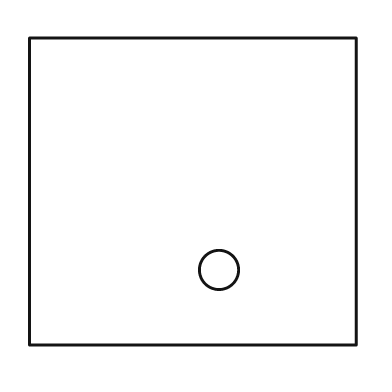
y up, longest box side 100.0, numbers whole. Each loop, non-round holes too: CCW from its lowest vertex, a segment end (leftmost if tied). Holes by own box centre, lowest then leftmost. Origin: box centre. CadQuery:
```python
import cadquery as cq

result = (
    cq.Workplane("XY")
    .moveTo(-50.0, -47.0)
    .lineTo(50.0, -47.0)
    .lineTo(50.0, 47.0)
    .lineTo(-50.0, 47.0)
    .close()
    .moveTo(8.0, -24.0)
    .circle(6.0)
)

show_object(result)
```